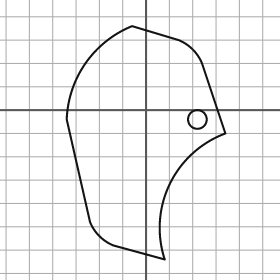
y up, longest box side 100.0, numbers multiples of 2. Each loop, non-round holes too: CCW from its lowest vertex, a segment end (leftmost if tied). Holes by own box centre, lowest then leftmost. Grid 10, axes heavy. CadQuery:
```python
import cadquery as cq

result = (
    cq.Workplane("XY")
    .moveTo(8.0, -64.0)
    .threePointArc((10.0, -32.0), (34.0, -10.0))
    .lineTo(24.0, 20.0)
    .threePointArc((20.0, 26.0), (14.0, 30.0))
    .lineTo(-6.0, 36.0)
    .threePointArc((-26.0, 20.0), (-34.0, -4.0))
    .lineTo(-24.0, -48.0)
    .threePointArc((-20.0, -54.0), (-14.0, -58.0))
    .close()
    .moveTo(22.0, -4.0)
    .circle(4.0)
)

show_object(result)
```